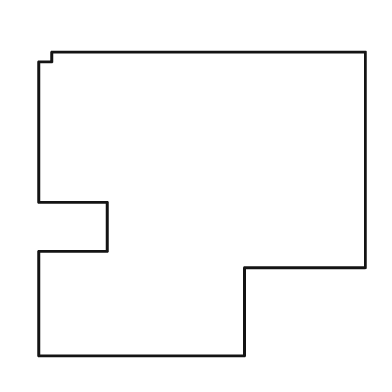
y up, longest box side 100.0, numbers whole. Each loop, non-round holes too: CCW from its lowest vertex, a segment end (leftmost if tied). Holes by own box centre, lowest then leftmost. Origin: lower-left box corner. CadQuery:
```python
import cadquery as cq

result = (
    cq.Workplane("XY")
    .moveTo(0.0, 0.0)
    .lineTo(63.0, 0.0)
    .lineTo(63.0, 27.0)
    .lineTo(100.0, 27.0)
    .lineTo(100.0, 93.0)
    .lineTo(4.0, 93.0)
    .lineTo(4.0, 90.0)
    .lineTo(0.0, 90.0)
    .lineTo(0.0, 47.0)
    .lineTo(21.0, 47.0)
    .lineTo(21.0, 32.0)
    .lineTo(0.0, 32.0)
    .close()
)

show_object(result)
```